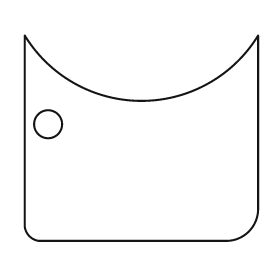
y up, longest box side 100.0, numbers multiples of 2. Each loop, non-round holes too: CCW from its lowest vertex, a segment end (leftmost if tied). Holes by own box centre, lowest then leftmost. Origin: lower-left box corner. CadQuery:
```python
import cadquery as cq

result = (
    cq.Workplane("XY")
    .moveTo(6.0, 0.0)
    .lineTo(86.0, 0.0)
    .threePointArc((96.0, 4.0), (100.0, 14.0))
    .lineTo(100.0, 88.0)
    .threePointArc((50.0, 60.0), (0.0, 88.0))
    .lineTo(0.0, 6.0)
    .threePointArc((2.0, 2.0), (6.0, 0.0))
    .close()
    .moveTo(10.0, 50.0)
    .circle(6.0)
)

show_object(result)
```